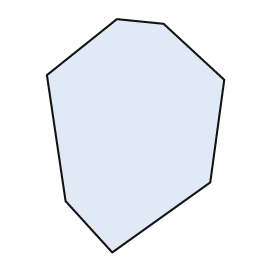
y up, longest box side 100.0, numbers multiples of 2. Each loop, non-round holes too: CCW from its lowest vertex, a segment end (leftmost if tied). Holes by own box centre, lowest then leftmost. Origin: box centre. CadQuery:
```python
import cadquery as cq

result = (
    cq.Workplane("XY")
    .moveTo(-10.0, -50.0)
    .lineTo(32.0, -20.0)
    .lineTo(38.0, 24.0)
    .lineTo(12.0, 48.0)
    .lineTo(-8.0, 50.0)
    .lineTo(-38.0, 26.0)
    .lineTo(-30.0, -28.0)
    .close()
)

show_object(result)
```